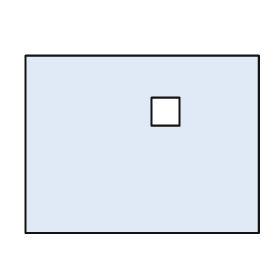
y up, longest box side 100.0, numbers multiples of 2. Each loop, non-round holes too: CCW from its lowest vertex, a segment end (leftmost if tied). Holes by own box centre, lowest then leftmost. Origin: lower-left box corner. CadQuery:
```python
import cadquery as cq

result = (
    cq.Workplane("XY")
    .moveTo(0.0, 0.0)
    .lineTo(100.0, 0.0)
    .lineTo(100.0, 76.0)
    .lineTo(0.0, 76.0)
    .close()
    .moveTo(54.0, 46.0)
    .lineTo(66.0, 46.0)
    .lineTo(66.0, 58.0)
    .lineTo(54.0, 58.0)
    .close()
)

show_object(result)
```